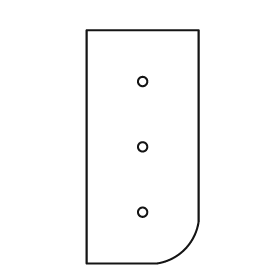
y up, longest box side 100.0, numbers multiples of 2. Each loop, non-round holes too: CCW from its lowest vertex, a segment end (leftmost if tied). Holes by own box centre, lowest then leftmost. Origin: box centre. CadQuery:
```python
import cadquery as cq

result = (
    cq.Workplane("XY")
    .moveTo(-24.0, -50.0)
    .lineTo(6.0, -50.0)
    .threePointArc((18.0, -44.0), (24.0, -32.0))
    .lineTo(24.0, 50.0)
    .lineTo(-24.0, 50.0)
    .close()
    .moveTo(0.0, -28.0)
    .circle(2.0)
    .moveTo(0.0, 0.0)
    .circle(2.0)
    .moveTo(0.0, 28.0)
    .circle(2.0)
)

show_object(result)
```